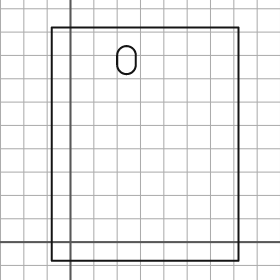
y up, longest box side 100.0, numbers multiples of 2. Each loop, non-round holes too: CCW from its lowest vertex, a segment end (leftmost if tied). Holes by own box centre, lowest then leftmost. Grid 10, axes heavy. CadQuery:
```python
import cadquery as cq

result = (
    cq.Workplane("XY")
    .moveTo(-8.0, -8.0)
    .lineTo(72.0, -8.0)
    .lineTo(72.0, 92.0)
    .lineTo(-8.0, 92.0)
    .close()
    .moveTo(20.0, 76.0)
    .threePointArc((24.0, 72.0), (28.0, 76.0))
    .lineTo(28.0, 80.0)
    .threePointArc((24.0, 84.0), (20.0, 80.0))
    .close()
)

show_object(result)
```